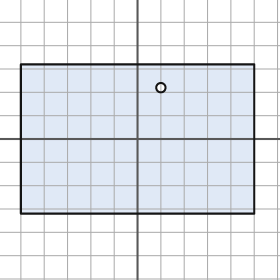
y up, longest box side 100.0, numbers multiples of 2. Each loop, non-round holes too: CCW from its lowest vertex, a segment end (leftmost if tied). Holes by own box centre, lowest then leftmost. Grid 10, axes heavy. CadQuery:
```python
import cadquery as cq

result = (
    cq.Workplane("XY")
    .moveTo(-50.0, -32.0)
    .lineTo(50.0, -32.0)
    .lineTo(50.0, 32.0)
    .lineTo(-50.0, 32.0)
    .close()
    .moveTo(10.0, 22.0)
    .circle(2.0)
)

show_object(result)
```